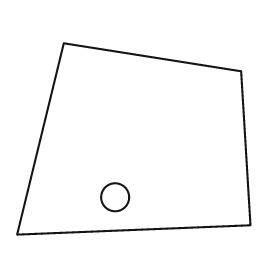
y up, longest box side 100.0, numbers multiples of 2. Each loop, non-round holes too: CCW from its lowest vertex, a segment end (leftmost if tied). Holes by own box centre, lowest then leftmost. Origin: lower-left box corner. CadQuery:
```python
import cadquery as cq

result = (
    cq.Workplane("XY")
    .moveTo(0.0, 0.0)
    .lineTo(100.0, 4.0)
    .lineTo(96.0, 70.0)
    .lineTo(20.0, 82.0)
    .close()
    .moveTo(42.0, 16.0)
    .circle(6.0)
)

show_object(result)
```